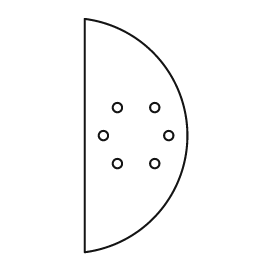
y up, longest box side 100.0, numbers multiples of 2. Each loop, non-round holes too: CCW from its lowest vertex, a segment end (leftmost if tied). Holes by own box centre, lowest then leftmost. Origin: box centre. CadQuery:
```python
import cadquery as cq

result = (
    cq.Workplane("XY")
    .moveTo(-22.0, -50.0)
    .threePointArc((22.0, 0.0), (-22.0, 50.0))
    .close()
    .moveTo(-8.0, -12.0)
    .circle(2.0)
    .moveTo(8.0, -12.0)
    .circle(2.0)
    .moveTo(-14.0, 0.0)
    .circle(2.0)
    .moveTo(14.0, 0.0)
    .circle(2.0)
    .moveTo(-8.0, 12.0)
    .circle(2.0)
    .moveTo(8.0, 12.0)
    .circle(2.0)
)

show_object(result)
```